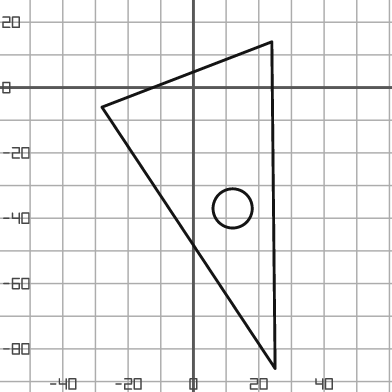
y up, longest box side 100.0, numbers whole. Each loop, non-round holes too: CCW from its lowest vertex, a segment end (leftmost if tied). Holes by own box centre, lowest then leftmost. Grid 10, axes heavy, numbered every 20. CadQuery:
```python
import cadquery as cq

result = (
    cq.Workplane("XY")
    .moveTo(25.0, -86.0)
    .lineTo(24.0, 14.0)
    .lineTo(-28.0, -6.0)
    .close()
    .moveTo(12.0, -37.0)
    .circle(6.0)
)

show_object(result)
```